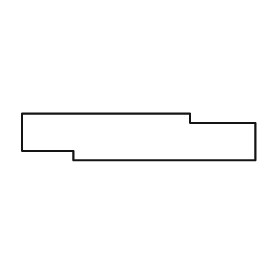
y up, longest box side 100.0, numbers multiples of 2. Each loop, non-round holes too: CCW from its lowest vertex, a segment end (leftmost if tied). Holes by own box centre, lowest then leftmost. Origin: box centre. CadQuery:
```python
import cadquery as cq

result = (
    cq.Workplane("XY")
    .moveTo(-28.0, -10.0)
    .lineTo(50.0, -10.0)
    .lineTo(50.0, 6.0)
    .lineTo(22.0, 6.0)
    .lineTo(22.0, 10.0)
    .lineTo(-50.0, 10.0)
    .lineTo(-50.0, -6.0)
    .lineTo(-28.0, -6.0)
    .close()
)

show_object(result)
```